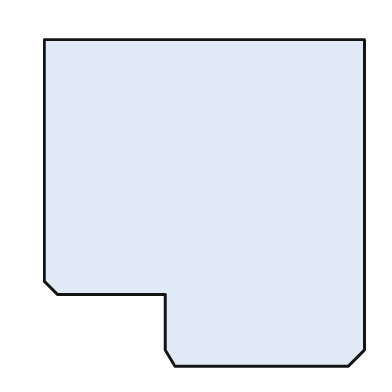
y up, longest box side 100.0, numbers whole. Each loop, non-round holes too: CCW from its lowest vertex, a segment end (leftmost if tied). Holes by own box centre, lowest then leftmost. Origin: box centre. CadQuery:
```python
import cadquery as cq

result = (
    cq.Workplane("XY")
    .moveTo(-9.0, -50.0)
    .lineTo(44.0, -50.0)
    .lineTo(49.0, -45.0)
    .lineTo(49.0, 50.0)
    .lineTo(-49.0, 50.0)
    .lineTo(-49.0, -24.0)
    .lineTo(-45.0, -28.0)
    .lineTo(-12.0, -28.0)
    .lineTo(-12.0, -45.0)
    .close()
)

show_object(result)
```